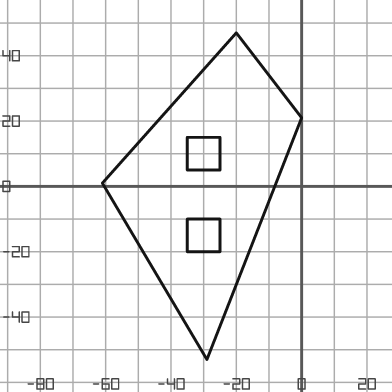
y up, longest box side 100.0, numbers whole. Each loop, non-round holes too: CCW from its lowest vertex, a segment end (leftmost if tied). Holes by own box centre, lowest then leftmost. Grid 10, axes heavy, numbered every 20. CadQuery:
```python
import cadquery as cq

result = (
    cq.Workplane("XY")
    .moveTo(-29.0, -53.0)
    .lineTo(0.0, 21.0)
    .lineTo(-20.0, 47.0)
    .lineTo(-61.0, 1.0)
    .close()
    .moveTo(-35.0, -20.0)
    .lineTo(-25.0, -20.0)
    .lineTo(-25.0, -10.0)
    .lineTo(-35.0, -10.0)
    .close()
    .moveTo(-35.0, 5.0)
    .lineTo(-25.0, 5.0)
    .lineTo(-25.0, 15.0)
    .lineTo(-35.0, 15.0)
    .close()
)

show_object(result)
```